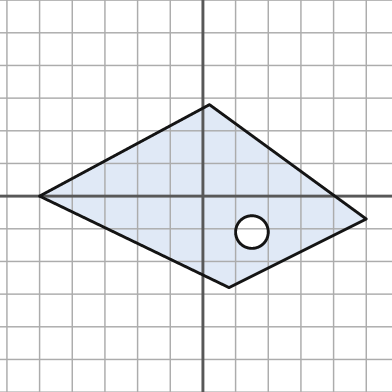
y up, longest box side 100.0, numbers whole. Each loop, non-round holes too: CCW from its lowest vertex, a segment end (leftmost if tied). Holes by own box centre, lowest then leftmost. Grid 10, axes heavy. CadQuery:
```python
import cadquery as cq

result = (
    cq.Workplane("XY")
    .moveTo(8.0, -28.0)
    .lineTo(50.0, -7.0)
    .lineTo(2.0, 28.0)
    .lineTo(-50.0, 0.0)
    .close()
    .moveTo(15.0, -11.0)
    .circle(5.0)
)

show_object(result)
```